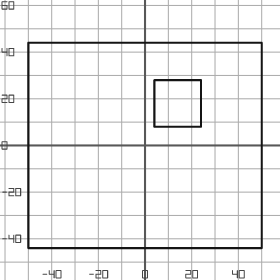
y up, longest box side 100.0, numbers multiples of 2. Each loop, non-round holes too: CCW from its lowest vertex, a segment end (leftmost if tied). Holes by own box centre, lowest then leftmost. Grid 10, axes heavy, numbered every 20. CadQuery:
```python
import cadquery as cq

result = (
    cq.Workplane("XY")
    .moveTo(-50.0, -44.0)
    .lineTo(50.0, -44.0)
    .lineTo(50.0, 44.0)
    .lineTo(-50.0, 44.0)
    .close()
    .moveTo(4.0, 8.0)
    .lineTo(24.0, 8.0)
    .lineTo(24.0, 28.0)
    .lineTo(4.0, 28.0)
    .close()
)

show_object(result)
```